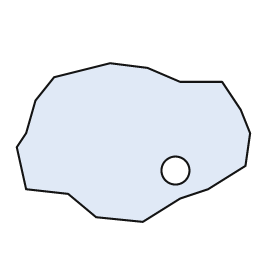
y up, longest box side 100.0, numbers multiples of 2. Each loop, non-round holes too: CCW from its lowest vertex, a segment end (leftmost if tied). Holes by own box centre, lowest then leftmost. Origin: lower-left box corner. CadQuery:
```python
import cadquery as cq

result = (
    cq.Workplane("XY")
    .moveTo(54.0, 0.0)
    .lineTo(70.0, 10.0)
    .lineTo(82.0, 14.0)
    .lineTo(98.0, 24.0)
    .lineTo(100.0, 38.0)
    .lineTo(96.0, 48.0)
    .lineTo(88.0, 60.0)
    .lineTo(70.0, 60.0)
    .lineTo(56.0, 66.0)
    .lineTo(40.0, 68.0)
    .lineTo(16.0, 62.0)
    .lineTo(8.0, 52.0)
    .lineTo(4.0, 38.0)
    .lineTo(0.0, 32.0)
    .lineTo(4.0, 14.0)
    .lineTo(22.0, 12.0)
    .lineTo(34.0, 2.0)
    .close()
    .moveTo(68.0, 22.0)
    .circle(6.0)
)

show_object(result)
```